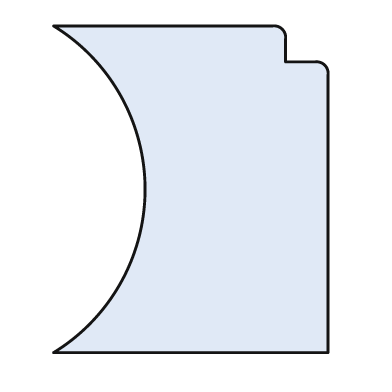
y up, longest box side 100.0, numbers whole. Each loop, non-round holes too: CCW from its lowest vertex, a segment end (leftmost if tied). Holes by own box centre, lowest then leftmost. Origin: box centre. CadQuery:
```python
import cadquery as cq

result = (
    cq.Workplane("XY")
    .moveTo(-42.0, -50.0)
    .lineTo(42.0, -50.0)
    .lineTo(42.0, 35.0)
    .threePointArc((41.0, 38.0), (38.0, 39.0))
    .lineTo(29.0, 39.0)
    .lineTo(29.0, 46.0)
    .threePointArc((28.0, 49.0), (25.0, 50.0))
    .lineTo(-42.0, 50.0)
    .threePointArc((-14.0, 0.0), (-42.0, -50.0))
    .close()
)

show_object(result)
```